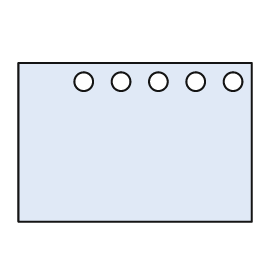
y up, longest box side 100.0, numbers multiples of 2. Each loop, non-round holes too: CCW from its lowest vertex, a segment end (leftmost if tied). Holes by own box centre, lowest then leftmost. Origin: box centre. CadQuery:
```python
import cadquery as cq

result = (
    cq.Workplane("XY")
    .moveTo(-50.0, -34.0)
    .lineTo(50.0, -34.0)
    .lineTo(50.0, 34.0)
    .lineTo(-50.0, 34.0)
    .close()
    .moveTo(-22.0, 26.0)
    .circle(4.0)
    .moveTo(-6.0, 26.0)
    .circle(4.0)
    .moveTo(10.0, 26.0)
    .circle(4.0)
    .moveTo(26.0, 26.0)
    .circle(4.0)
    .moveTo(42.0, 26.0)
    .circle(4.0)
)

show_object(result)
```